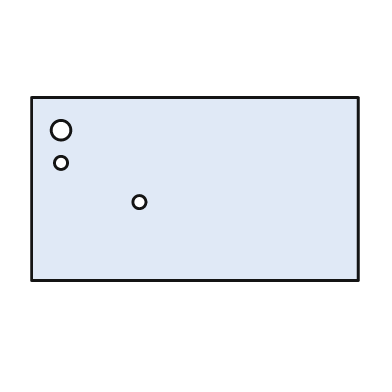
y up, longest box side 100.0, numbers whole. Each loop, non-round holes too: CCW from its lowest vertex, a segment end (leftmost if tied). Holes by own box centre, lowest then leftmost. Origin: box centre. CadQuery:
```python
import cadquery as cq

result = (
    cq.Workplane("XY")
    .moveTo(-50.0, -28.0)
    .lineTo(50.0, -28.0)
    .lineTo(50.0, 28.0)
    .lineTo(-50.0, 28.0)
    .close()
    .moveTo(-17.0, -4.0)
    .circle(2.0)
    .moveTo(-41.0, 8.0)
    .circle(2.0)
    .moveTo(-41.0, 18.0)
    .circle(3.0)
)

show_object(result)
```